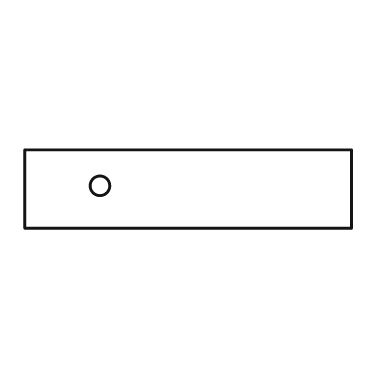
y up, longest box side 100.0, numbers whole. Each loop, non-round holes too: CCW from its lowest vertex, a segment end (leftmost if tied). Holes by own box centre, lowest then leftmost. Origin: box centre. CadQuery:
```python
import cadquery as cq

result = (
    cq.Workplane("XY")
    .moveTo(-50.0, -12.0)
    .lineTo(50.0, -12.0)
    .lineTo(50.0, 12.0)
    .lineTo(-50.0, 12.0)
    .close()
    .moveTo(-27.0, 1.0)
    .circle(3.0)
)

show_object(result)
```